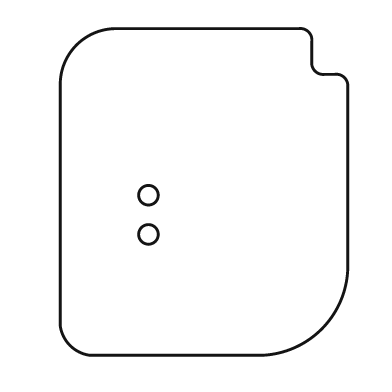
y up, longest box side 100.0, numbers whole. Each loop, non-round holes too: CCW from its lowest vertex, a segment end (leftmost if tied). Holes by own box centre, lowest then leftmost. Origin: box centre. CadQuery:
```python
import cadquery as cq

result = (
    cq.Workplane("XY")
    .moveTo(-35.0, -50.0)
    .lineTo(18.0, -50.0)
    .threePointArc((36.0, -42.0), (44.0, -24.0))
    .lineTo(44.0, 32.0)
    .threePointArc((43.0, 35.0), (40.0, 36.0))
    .lineTo(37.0, 36.0)
    .threePointArc((34.0, 37.0), (33.0, 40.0))
    .lineTo(33.0, 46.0)
    .threePointArc((32.0, 49.0), (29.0, 50.0))
    .lineTo(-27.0, 50.0)
    .threePointArc((-39.0, 45.0), (-44.0, 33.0))
    .lineTo(-44.0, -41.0)
    .threePointArc((-41.0, -47.0), (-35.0, -50.0))
    .close()
    .moveTo(-17.0, -13.0)
    .circle(3.0)
    .moveTo(-17.0, -1.0)
    .circle(3.0)
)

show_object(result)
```